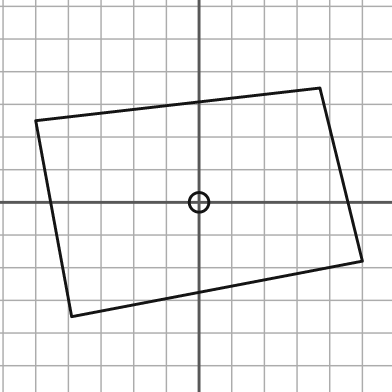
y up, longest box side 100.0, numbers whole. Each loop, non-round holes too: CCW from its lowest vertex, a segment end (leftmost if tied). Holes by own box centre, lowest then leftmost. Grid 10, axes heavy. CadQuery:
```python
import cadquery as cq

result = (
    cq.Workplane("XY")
    .moveTo(-39.0, -35.0)
    .lineTo(50.0, -18.0)
    .lineTo(37.0, 35.0)
    .lineTo(-50.0, 25.0)
    .close()
    .moveTo(0.0, 0.0)
    .circle(3.0)
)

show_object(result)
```